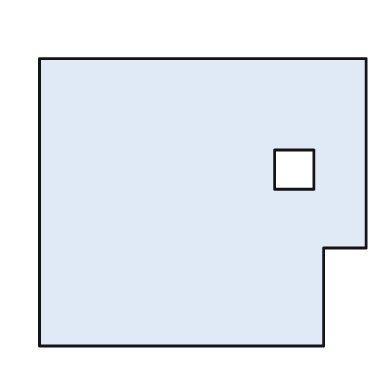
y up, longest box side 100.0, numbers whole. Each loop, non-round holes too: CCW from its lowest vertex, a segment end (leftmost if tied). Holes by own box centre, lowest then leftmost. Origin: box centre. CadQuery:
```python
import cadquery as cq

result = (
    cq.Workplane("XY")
    .moveTo(-50.0, -44.0)
    .lineTo(37.0, -44.0)
    .lineTo(37.0, -14.0)
    .lineTo(50.0, -14.0)
    .lineTo(50.0, 44.0)
    .lineTo(-50.0, 44.0)
    .close()
    .moveTo(22.0, 4.0)
    .lineTo(34.0, 4.0)
    .lineTo(34.0, 16.0)
    .lineTo(22.0, 16.0)
    .close()
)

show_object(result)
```